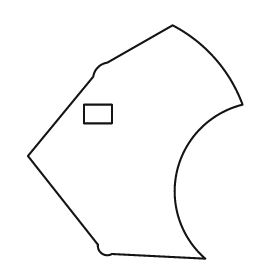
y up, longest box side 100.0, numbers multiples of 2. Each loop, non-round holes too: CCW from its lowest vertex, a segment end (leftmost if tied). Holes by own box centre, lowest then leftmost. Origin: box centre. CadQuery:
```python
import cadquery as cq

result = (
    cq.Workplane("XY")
    .moveTo(30.0, -50.0)
    .threePointArc((18.0, -12.0), (46.0, 16.0))
    .threePointArc((34.0, 36.0), (16.0, 50.0))
    .lineTo(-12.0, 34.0)
    .threePointArc((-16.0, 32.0), (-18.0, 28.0))
    .lineTo(-46.0, -6.0)
    .lineTo(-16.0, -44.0)
    .threePointArc((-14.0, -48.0), (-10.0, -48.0))
    .close()
    .moveTo(-22.0, 8.0)
    .lineTo(-10.0, 8.0)
    .lineTo(-10.0, 16.0)
    .lineTo(-22.0, 16.0)
    .close()
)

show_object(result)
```